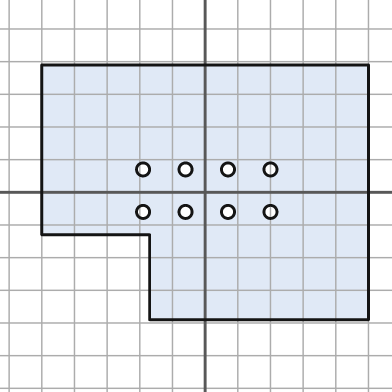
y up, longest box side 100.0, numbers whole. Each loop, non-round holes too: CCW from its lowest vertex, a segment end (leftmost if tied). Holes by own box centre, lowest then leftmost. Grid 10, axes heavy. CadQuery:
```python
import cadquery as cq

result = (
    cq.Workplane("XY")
    .moveTo(-17.0, -39.0)
    .lineTo(50.0, -39.0)
    .lineTo(50.0, 39.0)
    .lineTo(-50.0, 39.0)
    .lineTo(-50.0, -13.0)
    .lineTo(-17.0, -13.0)
    .close()
    .moveTo(-19.0, -6.0)
    .circle(2.0)
    .moveTo(-6.0, -6.0)
    .circle(2.0)
    .moveTo(7.0, -6.0)
    .circle(2.0)
    .moveTo(20.0, -6.0)
    .circle(2.0)
    .moveTo(-19.0, 7.0)
    .circle(2.0)
    .moveTo(-6.0, 7.0)
    .circle(2.0)
    .moveTo(7.0, 7.0)
    .circle(2.0)
    .moveTo(20.0, 7.0)
    .circle(2.0)
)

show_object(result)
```